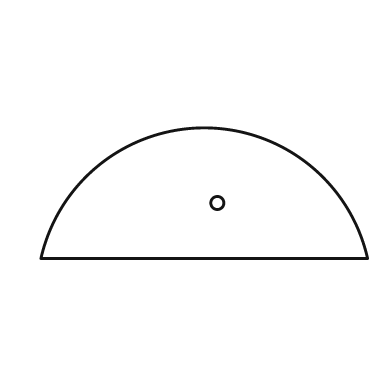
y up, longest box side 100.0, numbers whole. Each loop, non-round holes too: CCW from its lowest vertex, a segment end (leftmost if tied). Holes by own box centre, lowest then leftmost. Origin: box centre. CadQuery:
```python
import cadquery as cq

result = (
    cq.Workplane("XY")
    .moveTo(-50.0, -20.0)
    .lineTo(50.0, -20.0)
    .threePointArc((0.0, 20.0), (-50.0, -20.0))
    .close()
    .moveTo(4.0, -3.0)
    .circle(2.0)
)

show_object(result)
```